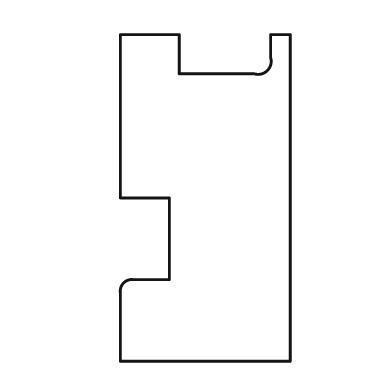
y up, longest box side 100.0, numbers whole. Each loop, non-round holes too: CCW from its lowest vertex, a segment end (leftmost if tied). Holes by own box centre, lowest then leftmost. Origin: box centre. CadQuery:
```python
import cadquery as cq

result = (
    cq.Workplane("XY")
    .moveTo(-26.0, -50.0)
    .lineTo(26.0, -50.0)
    .lineTo(26.0, 50.0)
    .lineTo(20.0, 50.0)
    .lineTo(20.0, 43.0)
    .threePointArc((19.0, 39.0), (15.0, 38.0))
    .lineTo(-8.0, 38.0)
    .lineTo(-8.0, 50.0)
    .lineTo(-26.0, 50.0)
    .lineTo(-26.0, 0.0)
    .lineTo(-11.0, 0.0)
    .lineTo(-11.0, -25.0)
    .lineTo(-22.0, -25.0)
    .threePointArc((-25.0, -26.0), (-26.0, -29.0))
    .close()
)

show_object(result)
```